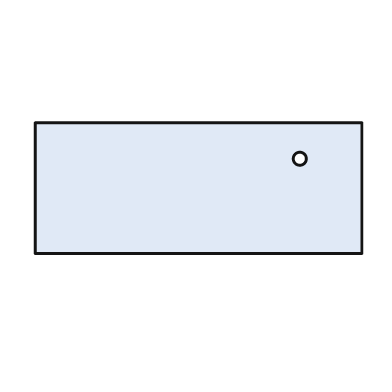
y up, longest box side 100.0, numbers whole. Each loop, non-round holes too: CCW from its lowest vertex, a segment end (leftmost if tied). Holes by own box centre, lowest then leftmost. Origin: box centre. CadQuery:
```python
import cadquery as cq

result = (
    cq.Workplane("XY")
    .moveTo(-50.0, -20.0)
    .lineTo(50.0, -20.0)
    .lineTo(50.0, 20.0)
    .lineTo(-50.0, 20.0)
    .close()
    .moveTo(31.0, 9.0)
    .circle(2.0)
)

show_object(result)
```